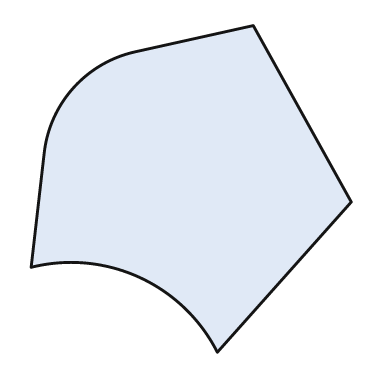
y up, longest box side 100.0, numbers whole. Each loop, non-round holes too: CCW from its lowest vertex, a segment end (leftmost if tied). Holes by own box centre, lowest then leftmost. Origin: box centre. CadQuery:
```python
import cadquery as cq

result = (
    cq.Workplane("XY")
    .moveTo(8.0, -50.0)
    .lineTo(49.0, -4.0)
    .lineTo(19.0, 50.0)
    .lineTo(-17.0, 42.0)
    .threePointArc((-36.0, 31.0), (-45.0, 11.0))
    .lineTo(-49.0, -24.0)
    .threePointArc((-16.0, -27.0), (8.0, -50.0))
    .close()
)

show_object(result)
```